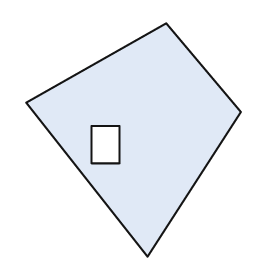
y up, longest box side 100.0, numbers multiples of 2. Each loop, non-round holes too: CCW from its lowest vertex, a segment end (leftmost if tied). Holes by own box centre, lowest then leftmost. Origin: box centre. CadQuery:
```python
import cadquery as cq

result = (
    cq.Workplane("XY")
    .moveTo(6.0, -50.0)
    .lineTo(46.0, 12.0)
    .lineTo(14.0, 50.0)
    .lineTo(-46.0, 16.0)
    .close()
    .moveTo(-18.0, -10.0)
    .lineTo(-6.0, -10.0)
    .lineTo(-6.0, 6.0)
    .lineTo(-18.0, 6.0)
    .close()
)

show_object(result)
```